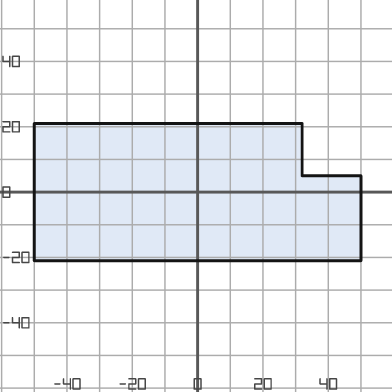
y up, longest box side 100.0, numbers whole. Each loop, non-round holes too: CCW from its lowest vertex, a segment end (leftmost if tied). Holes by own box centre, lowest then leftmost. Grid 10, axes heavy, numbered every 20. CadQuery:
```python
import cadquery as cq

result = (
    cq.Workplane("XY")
    .moveTo(-50.0, -21.0)
    .lineTo(50.0, -21.0)
    .lineTo(50.0, 5.0)
    .lineTo(32.0, 5.0)
    .lineTo(32.0, 21.0)
    .lineTo(-50.0, 21.0)
    .close()
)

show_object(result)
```